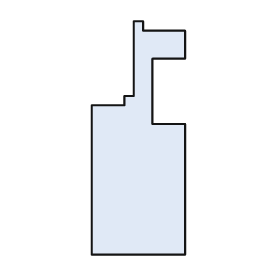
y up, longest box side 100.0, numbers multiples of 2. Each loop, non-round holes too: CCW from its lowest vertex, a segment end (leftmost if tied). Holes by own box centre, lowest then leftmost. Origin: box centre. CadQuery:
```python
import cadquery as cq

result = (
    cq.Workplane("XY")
    .moveTo(-20.0, -50.0)
    .lineTo(20.0, -50.0)
    .lineTo(20.0, 6.0)
    .lineTo(6.0, 6.0)
    .lineTo(6.0, 34.0)
    .lineTo(20.0, 34.0)
    .lineTo(20.0, 46.0)
    .lineTo(2.0, 46.0)
    .lineTo(2.0, 50.0)
    .lineTo(-2.0, 50.0)
    .lineTo(-2.0, 18.0)
    .lineTo(-6.0, 18.0)
    .lineTo(-6.0, 14.0)
    .lineTo(-20.0, 14.0)
    .close()
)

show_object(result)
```